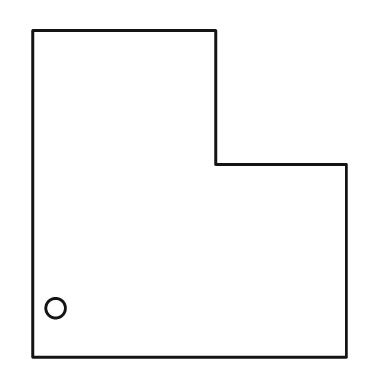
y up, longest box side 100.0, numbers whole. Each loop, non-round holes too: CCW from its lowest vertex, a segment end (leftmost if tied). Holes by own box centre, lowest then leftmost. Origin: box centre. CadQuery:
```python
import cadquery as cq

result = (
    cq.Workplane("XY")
    .moveTo(-48.0, -50.0)
    .lineTo(48.0, -50.0)
    .lineTo(48.0, 9.0)
    .lineTo(8.0, 9.0)
    .lineTo(8.0, 50.0)
    .lineTo(-48.0, 50.0)
    .close()
    .moveTo(-41.0, -35.0)
    .circle(3.0)
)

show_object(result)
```